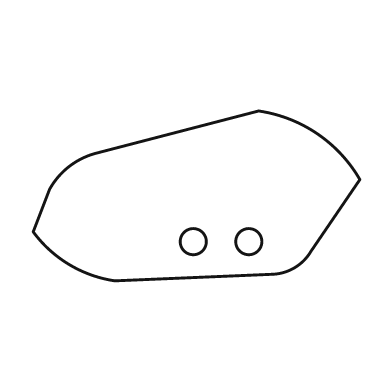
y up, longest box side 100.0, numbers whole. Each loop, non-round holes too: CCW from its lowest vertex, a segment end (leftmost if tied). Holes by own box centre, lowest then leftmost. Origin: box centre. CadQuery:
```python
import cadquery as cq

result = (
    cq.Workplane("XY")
    .moveTo(-25.0, -26.0)
    .lineTo(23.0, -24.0)
    .threePointArc((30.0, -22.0), (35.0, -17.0))
    .lineTo(50.0, 5.0)
    .threePointArc((37.0, 19.0), (19.0, 26.0))
    .lineTo(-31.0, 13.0)
    .threePointArc((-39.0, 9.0), (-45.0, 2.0))
    .lineTo(-50.0, -11.0)
    .threePointArc((-39.0, -21.0), (-25.0, -26.0))
    .close()
    .moveTo(-1.0, -14.0)
    .circle(4.0)
    .moveTo(16.0, -14.0)
    .circle(4.0)
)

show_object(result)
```